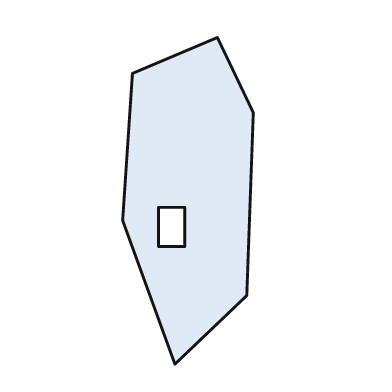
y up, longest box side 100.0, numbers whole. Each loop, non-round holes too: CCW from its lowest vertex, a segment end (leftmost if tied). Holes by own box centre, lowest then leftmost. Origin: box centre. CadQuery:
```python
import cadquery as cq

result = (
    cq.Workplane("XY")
    .moveTo(-4.0, -50.0)
    .lineTo(18.0, -29.0)
    .lineTo(20.0, 27.0)
    .lineTo(9.0, 50.0)
    .lineTo(-17.0, 39.0)
    .lineTo(-20.0, -6.0)
    .close()
    .moveTo(-9.0, -14.0)
    .lineTo(-1.0, -14.0)
    .lineTo(-1.0, -2.0)
    .lineTo(-9.0, -2.0)
    .close()
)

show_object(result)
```